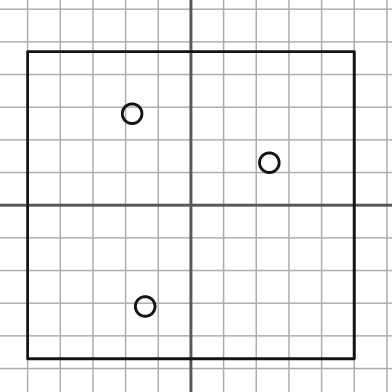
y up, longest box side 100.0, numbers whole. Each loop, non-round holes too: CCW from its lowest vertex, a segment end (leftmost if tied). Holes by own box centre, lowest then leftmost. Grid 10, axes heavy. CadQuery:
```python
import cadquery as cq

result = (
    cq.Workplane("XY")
    .moveTo(-50.0, -47.0)
    .lineTo(50.0, -47.0)
    .lineTo(50.0, 47.0)
    .lineTo(-50.0, 47.0)
    .close()
    .moveTo(-14.0, -31.0)
    .circle(3.0)
    .moveTo(24.0, 13.0)
    .circle(3.0)
    .moveTo(-18.0, 28.0)
    .circle(3.0)
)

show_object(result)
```